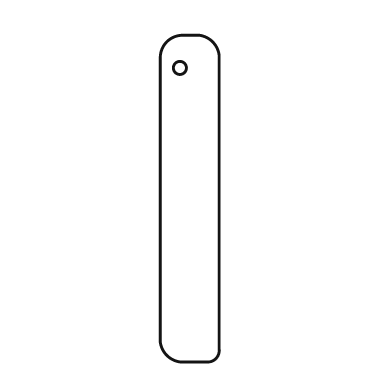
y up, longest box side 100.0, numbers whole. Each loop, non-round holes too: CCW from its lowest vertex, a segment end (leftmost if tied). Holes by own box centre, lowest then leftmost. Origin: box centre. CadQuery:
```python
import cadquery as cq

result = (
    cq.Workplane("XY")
    .moveTo(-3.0, -50.0)
    .lineTo(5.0, -50.0)
    .threePointArc((8.0, -49.0), (9.0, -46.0))
    .lineTo(9.0, 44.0)
    .threePointArc((7.0, 48.0), (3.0, 50.0))
    .lineTo(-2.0, 50.0)
    .threePointArc((-7.0, 48.0), (-9.0, 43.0))
    .lineTo(-9.0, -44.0)
    .threePointArc((-7.0, -48.0), (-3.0, -50.0))
    .close()
    .moveTo(-3.0, 40.0)
    .circle(2.0)
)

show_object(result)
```